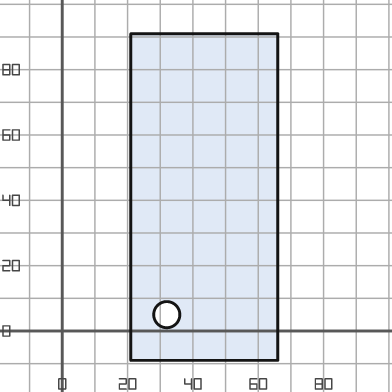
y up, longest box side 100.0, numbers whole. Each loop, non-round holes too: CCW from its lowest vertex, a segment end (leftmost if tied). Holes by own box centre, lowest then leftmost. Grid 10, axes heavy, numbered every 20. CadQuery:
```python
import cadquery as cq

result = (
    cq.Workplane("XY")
    .moveTo(21.0, -9.0)
    .lineTo(66.0, -9.0)
    .lineTo(66.0, 91.0)
    .lineTo(21.0, 91.0)
    .close()
    .moveTo(32.0, 5.0)
    .circle(4.0)
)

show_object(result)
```